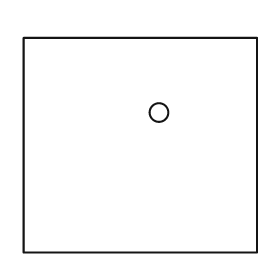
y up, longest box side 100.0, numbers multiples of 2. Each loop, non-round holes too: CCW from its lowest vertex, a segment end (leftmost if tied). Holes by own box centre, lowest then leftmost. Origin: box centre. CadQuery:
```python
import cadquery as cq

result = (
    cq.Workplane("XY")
    .moveTo(-50.0, -46.0)
    .lineTo(50.0, -46.0)
    .lineTo(50.0, 46.0)
    .lineTo(-50.0, 46.0)
    .close()
    .moveTo(8.0, 14.0)
    .circle(4.0)
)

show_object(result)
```